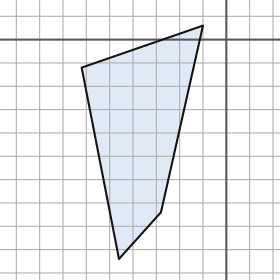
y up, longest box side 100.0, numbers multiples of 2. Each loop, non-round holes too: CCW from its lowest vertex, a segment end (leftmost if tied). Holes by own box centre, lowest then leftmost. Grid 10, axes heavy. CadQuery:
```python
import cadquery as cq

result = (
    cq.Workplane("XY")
    .moveTo(-46.0, -94.0)
    .lineTo(-28.0, -74.0)
    .lineTo(-10.0, 6.0)
    .lineTo(-62.0, -12.0)
    .close()
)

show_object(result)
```